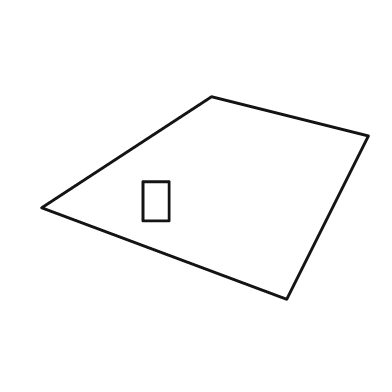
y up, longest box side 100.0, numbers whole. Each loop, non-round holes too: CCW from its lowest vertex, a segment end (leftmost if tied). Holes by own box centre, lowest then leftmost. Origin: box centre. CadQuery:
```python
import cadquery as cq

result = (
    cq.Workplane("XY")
    .moveTo(25.0, -31.0)
    .lineTo(50.0, 19.0)
    .lineTo(2.0, 31.0)
    .lineTo(-50.0, -3.0)
    .close()
    .moveTo(-19.0, -7.0)
    .lineTo(-11.0, -7.0)
    .lineTo(-11.0, 5.0)
    .lineTo(-19.0, 5.0)
    .close()
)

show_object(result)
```